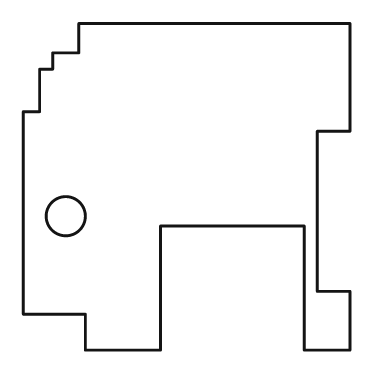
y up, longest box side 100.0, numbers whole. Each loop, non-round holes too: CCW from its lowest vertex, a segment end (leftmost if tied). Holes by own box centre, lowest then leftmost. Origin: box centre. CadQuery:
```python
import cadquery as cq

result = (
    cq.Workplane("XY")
    .moveTo(-31.0, -50.0)
    .lineTo(-8.0, -50.0)
    .lineTo(-8.0, -12.0)
    .lineTo(36.0, -12.0)
    .lineTo(36.0, -50.0)
    .lineTo(50.0, -50.0)
    .lineTo(50.0, -32.0)
    .lineTo(40.0, -32.0)
    .lineTo(40.0, 17.0)
    .lineTo(50.0, 17.0)
    .lineTo(50.0, 50.0)
    .lineTo(-33.0, 50.0)
    .lineTo(-33.0, 41.0)
    .lineTo(-41.0, 41.0)
    .lineTo(-41.0, 36.0)
    .lineTo(-45.0, 36.0)
    .lineTo(-45.0, 23.0)
    .lineTo(-50.0, 23.0)
    .lineTo(-50.0, -39.0)
    .lineTo(-31.0, -39.0)
    .close()
    .moveTo(-37.0, -9.0)
    .circle(6.0)
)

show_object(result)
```